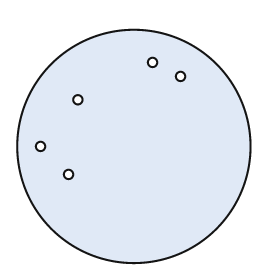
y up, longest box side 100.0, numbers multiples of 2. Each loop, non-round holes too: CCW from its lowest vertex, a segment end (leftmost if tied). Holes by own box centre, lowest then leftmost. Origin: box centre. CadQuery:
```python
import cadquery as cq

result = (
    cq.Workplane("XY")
    .moveTo(0.0, 0.0)
    .circle(50.0)
    .moveTo(-28.0, -12.0)
    .circle(2.0)
    .moveTo(-40.0, 0.0)
    .circle(2.0)
    .moveTo(-24.0, 20.0)
    .circle(2.0)
    .moveTo(20.0, 30.0)
    .circle(2.0)
    .moveTo(8.0, 36.0)
    .circle(2.0)
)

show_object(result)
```